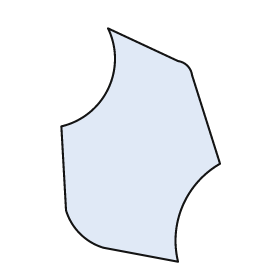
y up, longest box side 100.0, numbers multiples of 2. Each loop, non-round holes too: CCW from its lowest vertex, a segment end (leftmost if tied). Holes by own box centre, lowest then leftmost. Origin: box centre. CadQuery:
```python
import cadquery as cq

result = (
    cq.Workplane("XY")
    .moveTo(16.0, -50.0)
    .threePointArc((18.0, -26.0), (34.0, -8.0))
    .lineTo(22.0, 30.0)
    .threePointArc((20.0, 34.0), (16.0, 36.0))
    .lineTo(-14.0, 50.0)
    .threePointArc((-14.0, 24.0), (-34.0, 8.0))
    .lineTo(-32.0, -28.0)
    .threePointArc((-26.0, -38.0), (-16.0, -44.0))
    .close()
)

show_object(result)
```